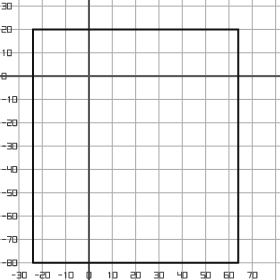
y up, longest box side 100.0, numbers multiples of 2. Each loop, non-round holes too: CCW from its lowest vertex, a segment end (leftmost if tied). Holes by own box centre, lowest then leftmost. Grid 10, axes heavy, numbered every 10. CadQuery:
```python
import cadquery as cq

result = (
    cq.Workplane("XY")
    .moveTo(-24.0, -80.0)
    .lineTo(64.0, -80.0)
    .lineTo(64.0, 20.0)
    .lineTo(-24.0, 20.0)
    .close()
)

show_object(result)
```